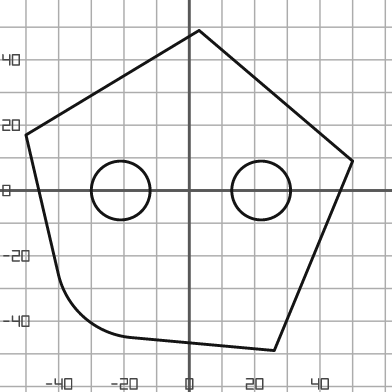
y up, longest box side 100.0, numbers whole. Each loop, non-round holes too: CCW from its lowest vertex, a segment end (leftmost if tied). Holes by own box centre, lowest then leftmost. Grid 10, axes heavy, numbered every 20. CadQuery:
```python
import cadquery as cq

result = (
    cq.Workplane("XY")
    .moveTo(26.0, -49.0)
    .lineTo(50.0, 9.0)
    .lineTo(3.0, 49.0)
    .lineTo(-50.0, 17.0)
    .lineTo(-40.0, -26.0)
    .threePointArc((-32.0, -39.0), (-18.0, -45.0))
    .close()
    .moveTo(-21.0, 0.0)
    .circle(9.0)
    .moveTo(22.0, 0.0)
    .circle(9.0)
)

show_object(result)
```